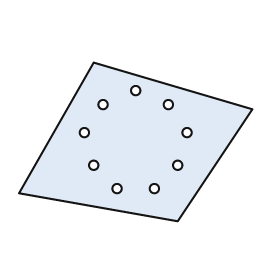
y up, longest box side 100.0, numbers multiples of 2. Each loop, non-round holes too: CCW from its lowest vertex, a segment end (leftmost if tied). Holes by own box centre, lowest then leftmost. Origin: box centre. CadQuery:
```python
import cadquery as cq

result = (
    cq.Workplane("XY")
    .moveTo(18.0, -34.0)
    .lineTo(50.0, 14.0)
    .lineTo(-18.0, 34.0)
    .lineTo(-50.0, -22.0)
    .close()
    .moveTo(-8.0, -20.0)
    .circle(2.0)
    .moveTo(8.0, -20.0)
    .circle(2.0)
    .moveTo(-18.0, -10.0)
    .circle(2.0)
    .moveTo(18.0, -10.0)
    .circle(2.0)
    .moveTo(-22.0, 4.0)
    .circle(2.0)
    .moveTo(22.0, 4.0)
    .circle(2.0)
    .moveTo(-14.0, 16.0)
    .circle(2.0)
    .moveTo(14.0, 16.0)
    .circle(2.0)
    .moveTo(0.0, 22.0)
    .circle(2.0)
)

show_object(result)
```